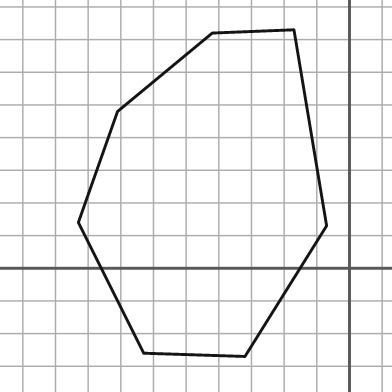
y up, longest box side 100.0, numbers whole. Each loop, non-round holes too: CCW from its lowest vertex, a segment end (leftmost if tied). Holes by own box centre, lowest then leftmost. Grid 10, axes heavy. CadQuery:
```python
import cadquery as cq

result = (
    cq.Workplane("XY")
    .moveTo(-32.0, -27.0)
    .lineTo(-7.0, 13.0)
    .lineTo(-17.0, 73.0)
    .lineTo(-42.0, 72.0)
    .lineTo(-71.0, 48.0)
    .lineTo(-83.0, 14.0)
    .lineTo(-63.0, -26.0)
    .close()
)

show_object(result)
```